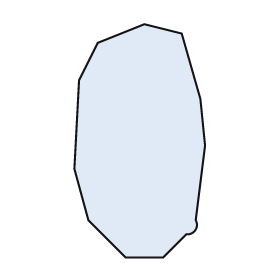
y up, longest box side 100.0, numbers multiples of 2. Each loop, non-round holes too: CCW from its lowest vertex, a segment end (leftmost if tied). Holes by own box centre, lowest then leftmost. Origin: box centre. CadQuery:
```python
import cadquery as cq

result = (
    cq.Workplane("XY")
    .moveTo(-6.0, -50.0)
    .lineTo(10.0, -50.0)
    .lineTo(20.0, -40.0)
    .threePointArc((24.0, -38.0), (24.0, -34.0))
    .lineTo(28.0, -2.0)
    .lineTo(26.0, 18.0)
    .lineTo(18.0, 46.0)
    .lineTo(2.0, 50.0)
    .lineTo(-18.0, 42.0)
    .lineTo(-26.0, 26.0)
    .lineTo(-28.0, -12.0)
    .lineTo(-22.0, -34.0)
    .close()
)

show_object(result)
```